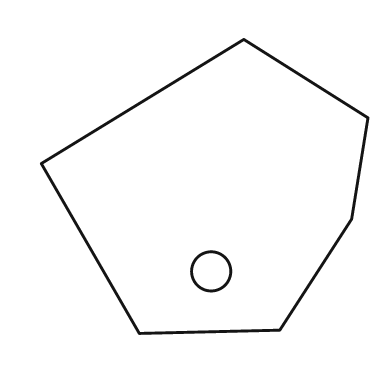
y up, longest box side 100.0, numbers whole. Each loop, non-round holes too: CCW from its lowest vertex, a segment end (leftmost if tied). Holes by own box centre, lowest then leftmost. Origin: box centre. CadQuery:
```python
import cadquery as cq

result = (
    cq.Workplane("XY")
    .moveTo(-20.0, -45.0)
    .lineTo(23.0, -44.0)
    .lineTo(45.0, -10.0)
    .lineTo(50.0, 21.0)
    .lineTo(12.0, 45.0)
    .lineTo(-50.0, 7.0)
    .close()
    .moveTo(2.0, -26.0)
    .circle(6.0)
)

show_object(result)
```